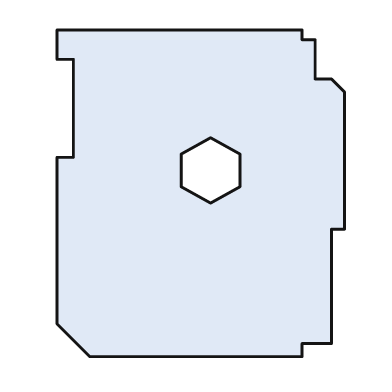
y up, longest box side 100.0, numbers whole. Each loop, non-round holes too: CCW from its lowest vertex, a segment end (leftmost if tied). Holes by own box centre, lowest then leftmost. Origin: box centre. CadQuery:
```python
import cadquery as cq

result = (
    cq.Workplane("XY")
    .moveTo(-34.0, -50.0)
    .lineTo(31.0, -50.0)
    .lineTo(31.0, -46.0)
    .lineTo(40.0, -46.0)
    .lineTo(40.0, -11.0)
    .lineTo(44.0, -11.0)
    .lineTo(44.0, 31.0)
    .lineTo(40.0, 35.0)
    .lineTo(35.0, 35.0)
    .lineTo(35.0, 47.0)
    .lineTo(31.0, 47.0)
    .lineTo(31.0, 50.0)
    .lineTo(-44.0, 50.0)
    .lineTo(-44.0, 41.0)
    .lineTo(-39.0, 41.0)
    .lineTo(-39.0, 11.0)
    .lineTo(-44.0, 11.0)
    .lineTo(-44.0, -40.0)
    .close()
    .moveTo(3.0, -3.0)
    .lineTo(12.0, 2.0)
    .lineTo(12.0, 12.0)
    .lineTo(3.0, 17.0)
    .lineTo(-6.0, 12.0)
    .lineTo(-6.0, 2.0)
    .close()
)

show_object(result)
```